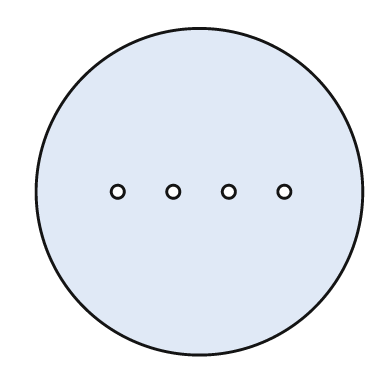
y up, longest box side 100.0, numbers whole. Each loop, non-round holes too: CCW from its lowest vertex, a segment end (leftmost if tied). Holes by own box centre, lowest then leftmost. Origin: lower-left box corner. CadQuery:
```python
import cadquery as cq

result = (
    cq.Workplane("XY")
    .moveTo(50.0, 50.0)
    .circle(50.0)
    .moveTo(25.0, 50.0)
    .circle(2.0)
    .moveTo(42.0, 50.0)
    .circle(2.0)
    .moveTo(59.0, 50.0)
    .circle(2.0)
    .moveTo(76.0, 50.0)
    .circle(2.0)
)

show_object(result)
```